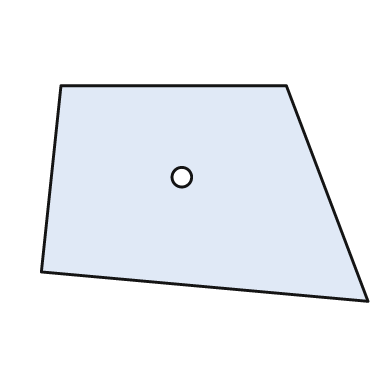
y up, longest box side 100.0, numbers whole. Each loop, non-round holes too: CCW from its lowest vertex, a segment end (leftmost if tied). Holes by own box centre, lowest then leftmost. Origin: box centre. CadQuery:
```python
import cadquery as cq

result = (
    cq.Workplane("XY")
    .moveTo(50.0, -33.0)
    .lineTo(25.0, 33.0)
    .lineTo(-44.0, 33.0)
    .lineTo(-50.0, -24.0)
    .close()
    .moveTo(-7.0, 5.0)
    .circle(3.0)
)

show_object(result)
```